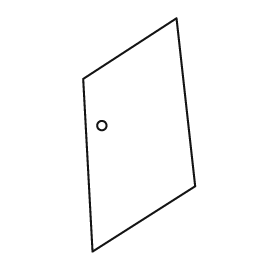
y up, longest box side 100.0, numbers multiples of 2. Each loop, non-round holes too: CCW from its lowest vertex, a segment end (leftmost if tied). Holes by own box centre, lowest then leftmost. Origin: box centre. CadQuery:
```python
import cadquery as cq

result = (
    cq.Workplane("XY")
    .moveTo(-20.0, -50.0)
    .lineTo(24.0, -22.0)
    .lineTo(16.0, 50.0)
    .lineTo(-24.0, 24.0)
    .close()
    .moveTo(-16.0, 4.0)
    .circle(2.0)
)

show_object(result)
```